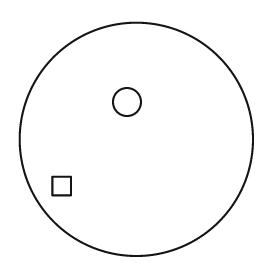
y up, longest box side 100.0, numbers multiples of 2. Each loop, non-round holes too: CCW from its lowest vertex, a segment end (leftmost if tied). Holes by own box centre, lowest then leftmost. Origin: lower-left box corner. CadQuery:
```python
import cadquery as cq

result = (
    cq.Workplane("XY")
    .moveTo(50.0, 50.0)
    .circle(50.0)
    .moveTo(14.0, 26.0)
    .lineTo(22.0, 26.0)
    .lineTo(22.0, 34.0)
    .lineTo(14.0, 34.0)
    .close()
    .moveTo(46.0, 66.0)
    .circle(6.0)
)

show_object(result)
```